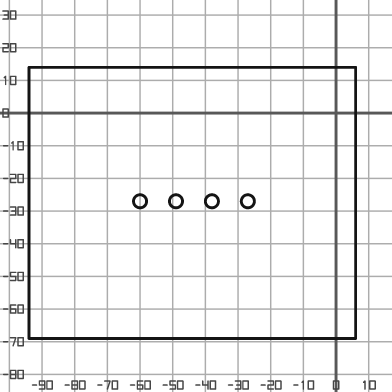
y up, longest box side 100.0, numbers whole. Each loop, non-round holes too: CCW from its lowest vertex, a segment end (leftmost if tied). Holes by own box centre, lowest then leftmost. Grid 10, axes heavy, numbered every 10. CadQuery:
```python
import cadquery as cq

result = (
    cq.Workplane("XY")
    .moveTo(-94.0, -69.0)
    .lineTo(6.0, -69.0)
    .lineTo(6.0, 14.0)
    .lineTo(-94.0, 14.0)
    .close()
    .moveTo(-60.0, -27.0)
    .circle(2.0)
    .moveTo(-49.0, -27.0)
    .circle(2.0)
    .moveTo(-38.0, -27.0)
    .circle(2.0)
    .moveTo(-27.0, -27.0)
    .circle(2.0)
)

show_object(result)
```